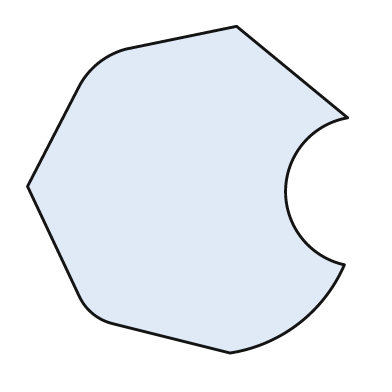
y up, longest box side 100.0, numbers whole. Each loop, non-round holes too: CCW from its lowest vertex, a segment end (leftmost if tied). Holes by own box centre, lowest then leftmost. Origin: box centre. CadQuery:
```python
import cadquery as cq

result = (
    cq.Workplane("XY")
    .moveTo(13.0, -50.0)
    .threePointArc((34.0, -41.0), (48.0, -23.0))
    .threePointArc((30.0, 0.0), (49.0, 22.0))
    .lineTo(15.0, 50.0)
    .lineTo(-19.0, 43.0)
    .threePointArc((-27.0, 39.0), (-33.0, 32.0))
    .lineTo(-49.0, 1.0)
    .lineTo(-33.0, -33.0)
    .threePointArc((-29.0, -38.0), (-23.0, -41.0))
    .close()
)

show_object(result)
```